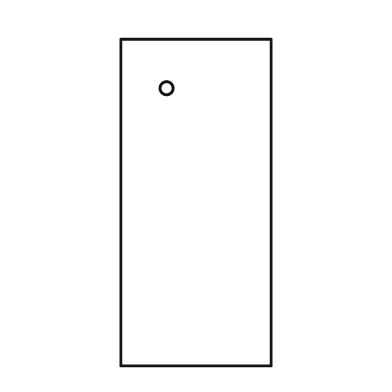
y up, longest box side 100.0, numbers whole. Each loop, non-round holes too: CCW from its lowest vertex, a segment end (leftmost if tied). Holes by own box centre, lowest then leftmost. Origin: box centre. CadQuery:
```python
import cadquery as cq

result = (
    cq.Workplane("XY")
    .moveTo(-23.0, -50.0)
    .lineTo(23.0, -50.0)
    .lineTo(23.0, 50.0)
    .lineTo(-23.0, 50.0)
    .close()
    .moveTo(-9.0, 35.0)
    .circle(2.0)
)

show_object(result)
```